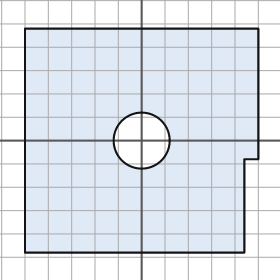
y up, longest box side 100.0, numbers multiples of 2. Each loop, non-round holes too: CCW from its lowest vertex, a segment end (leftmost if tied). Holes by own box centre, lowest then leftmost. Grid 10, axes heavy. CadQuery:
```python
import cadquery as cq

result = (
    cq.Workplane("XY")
    .moveTo(-50.0, -48.0)
    .lineTo(44.0, -48.0)
    .lineTo(44.0, -8.0)
    .lineTo(50.0, -8.0)
    .lineTo(50.0, 48.0)
    .lineTo(-50.0, 48.0)
    .close()
    .moveTo(0.0, 0.0)
    .circle(12.0)
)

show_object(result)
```